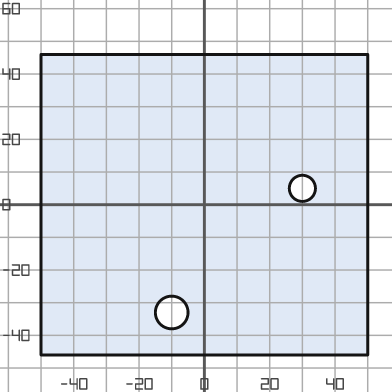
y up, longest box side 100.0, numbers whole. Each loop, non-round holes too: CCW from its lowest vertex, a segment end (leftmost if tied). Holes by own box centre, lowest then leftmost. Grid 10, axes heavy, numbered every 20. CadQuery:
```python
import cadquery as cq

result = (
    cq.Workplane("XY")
    .moveTo(-50.0, -46.0)
    .lineTo(50.0, -46.0)
    .lineTo(50.0, 46.0)
    .lineTo(-50.0, 46.0)
    .close()
    .moveTo(-10.0, -33.0)
    .circle(5.0)
    .moveTo(30.0, 5.0)
    .circle(4.0)
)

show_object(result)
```